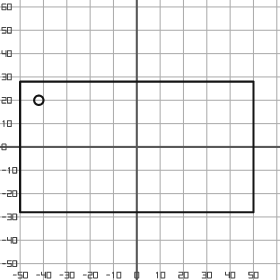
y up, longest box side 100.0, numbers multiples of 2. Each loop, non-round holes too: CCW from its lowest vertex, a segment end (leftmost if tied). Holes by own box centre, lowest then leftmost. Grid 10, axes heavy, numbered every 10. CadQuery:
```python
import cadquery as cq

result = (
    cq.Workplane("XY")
    .moveTo(-50.0, -28.0)
    .lineTo(50.0, -28.0)
    .lineTo(50.0, 28.0)
    .lineTo(-50.0, 28.0)
    .close()
    .moveTo(-42.0, 20.0)
    .circle(2.0)
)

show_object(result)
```